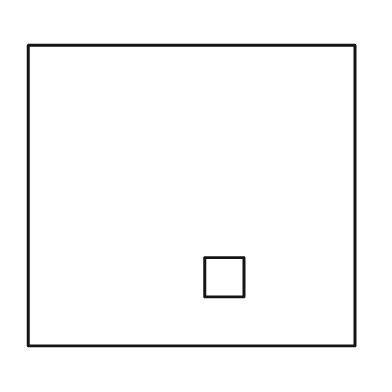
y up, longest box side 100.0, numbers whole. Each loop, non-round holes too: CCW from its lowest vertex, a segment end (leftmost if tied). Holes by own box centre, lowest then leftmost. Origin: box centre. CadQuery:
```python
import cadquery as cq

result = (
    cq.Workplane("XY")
    .moveTo(-50.0, -46.0)
    .lineTo(50.0, -46.0)
    .lineTo(50.0, 46.0)
    .lineTo(-50.0, 46.0)
    .close()
    .moveTo(4.0, -31.0)
    .lineTo(16.0, -31.0)
    .lineTo(16.0, -19.0)
    .lineTo(4.0, -19.0)
    .close()
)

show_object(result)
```